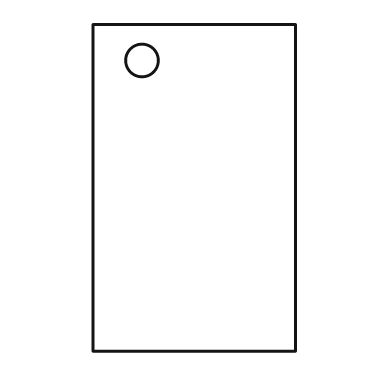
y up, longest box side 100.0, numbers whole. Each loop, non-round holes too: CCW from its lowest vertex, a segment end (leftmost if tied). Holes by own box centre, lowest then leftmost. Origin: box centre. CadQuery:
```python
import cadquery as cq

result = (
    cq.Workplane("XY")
    .moveTo(-31.0, -50.0)
    .lineTo(31.0, -50.0)
    .lineTo(31.0, 50.0)
    .lineTo(-31.0, 50.0)
    .close()
    .moveTo(-16.0, 39.0)
    .circle(5.0)
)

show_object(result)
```